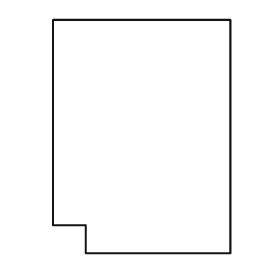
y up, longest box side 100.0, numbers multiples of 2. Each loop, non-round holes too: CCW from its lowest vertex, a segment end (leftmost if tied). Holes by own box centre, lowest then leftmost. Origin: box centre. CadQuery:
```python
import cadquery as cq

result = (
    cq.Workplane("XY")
    .moveTo(-24.0, -50.0)
    .lineTo(38.0, -50.0)
    .lineTo(38.0, 50.0)
    .lineTo(-38.0, 50.0)
    .lineTo(-38.0, -38.0)
    .lineTo(-24.0, -38.0)
    .close()
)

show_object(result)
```